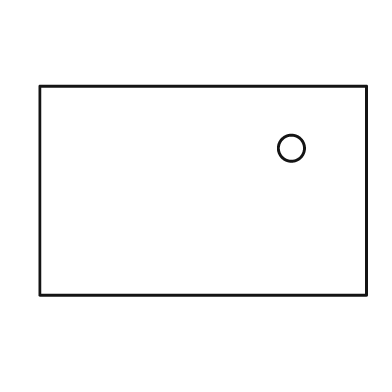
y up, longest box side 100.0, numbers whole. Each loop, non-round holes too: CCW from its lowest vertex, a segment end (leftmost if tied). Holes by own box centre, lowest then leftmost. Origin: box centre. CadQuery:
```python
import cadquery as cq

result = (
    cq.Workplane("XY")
    .moveTo(-50.0, -32.0)
    .lineTo(50.0, -32.0)
    .lineTo(50.0, 32.0)
    .lineTo(-50.0, 32.0)
    .close()
    .moveTo(27.0, 13.0)
    .circle(4.0)
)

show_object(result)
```